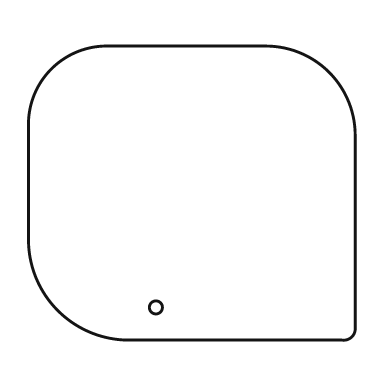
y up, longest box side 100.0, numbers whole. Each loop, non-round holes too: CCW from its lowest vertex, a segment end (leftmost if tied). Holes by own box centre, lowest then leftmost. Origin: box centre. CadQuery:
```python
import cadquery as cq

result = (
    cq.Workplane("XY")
    .moveTo(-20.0, -45.0)
    .lineTo(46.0, -45.0)
    .threePointArc((49.0, -44.0), (50.0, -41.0))
    .lineTo(50.0, 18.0)
    .threePointArc((42.0, 37.0), (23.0, 45.0))
    .lineTo(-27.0, 45.0)
    .threePointArc((-43.0, 38.0), (-50.0, 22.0))
    .lineTo(-50.0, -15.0)
    .threePointArc((-41.0, -36.0), (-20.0, -45.0))
    .close()
    .moveTo(-11.0, -35.0)
    .circle(2.0)
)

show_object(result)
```